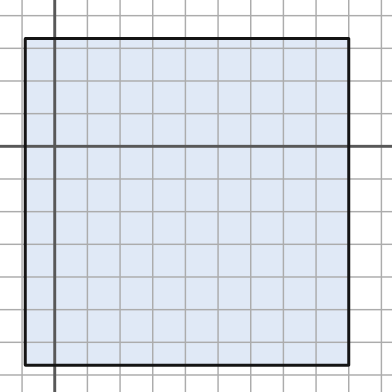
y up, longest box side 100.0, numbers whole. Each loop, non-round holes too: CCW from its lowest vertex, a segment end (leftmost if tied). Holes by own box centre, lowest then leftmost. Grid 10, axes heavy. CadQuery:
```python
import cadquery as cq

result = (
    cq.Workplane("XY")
    .moveTo(-9.0, -67.0)
    .lineTo(90.0, -67.0)
    .lineTo(90.0, 33.0)
    .lineTo(-9.0, 33.0)
    .close()
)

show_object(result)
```